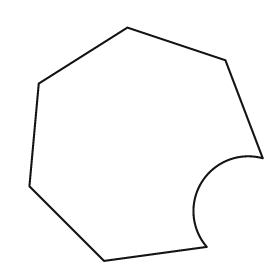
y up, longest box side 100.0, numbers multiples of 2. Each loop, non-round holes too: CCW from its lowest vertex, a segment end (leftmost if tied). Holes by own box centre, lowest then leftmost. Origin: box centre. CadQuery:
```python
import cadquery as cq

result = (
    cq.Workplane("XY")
    .moveTo(-18.0, -50.0)
    .lineTo(26.0, -44.0)
    .threePointArc((24.0, -16.0), (50.0, -6.0))
    .lineTo(34.0, 36.0)
    .lineTo(-8.0, 50.0)
    .lineTo(-46.0, 26.0)
    .lineTo(-50.0, -18.0)
    .close()
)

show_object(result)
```